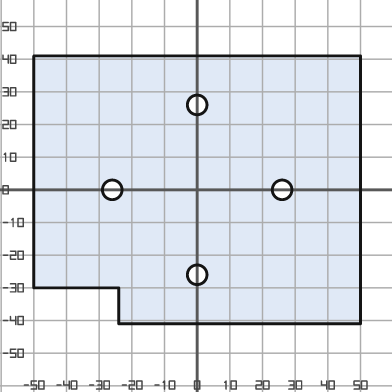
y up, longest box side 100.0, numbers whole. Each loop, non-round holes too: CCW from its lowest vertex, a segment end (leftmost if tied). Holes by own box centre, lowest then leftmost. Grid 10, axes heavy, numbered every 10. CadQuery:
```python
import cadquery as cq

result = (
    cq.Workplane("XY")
    .moveTo(-24.0, -41.0)
    .lineTo(50.0, -41.0)
    .lineTo(50.0, 41.0)
    .lineTo(-50.0, 41.0)
    .lineTo(-50.0, -30.0)
    .lineTo(-24.0, -30.0)
    .close()
    .moveTo(0.0, -26.0)
    .circle(3.0)
    .moveTo(-26.0, 0.0)
    .circle(3.0)
    .moveTo(26.0, 0.0)
    .circle(3.0)
    .moveTo(0.0, 26.0)
    .circle(3.0)
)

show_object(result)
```